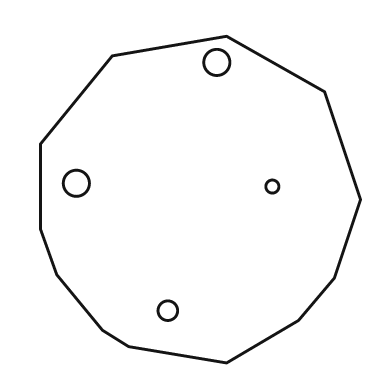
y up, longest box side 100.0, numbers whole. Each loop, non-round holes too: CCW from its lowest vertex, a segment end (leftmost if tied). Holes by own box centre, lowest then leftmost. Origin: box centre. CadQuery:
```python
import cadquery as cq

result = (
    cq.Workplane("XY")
    .moveTo(8.0, -50.0)
    .lineTo(30.0, -37.0)
    .lineTo(41.0, -24.0)
    .lineTo(49.0, 0.0)
    .lineTo(38.0, 33.0)
    .lineTo(8.0, 50.0)
    .lineTo(-27.0, 44.0)
    .lineTo(-49.0, 17.0)
    .lineTo(-49.0, -9.0)
    .lineTo(-44.0, -23.0)
    .lineTo(-30.0, -40.0)
    .lineTo(-22.0, -45.0)
    .close()
    .moveTo(-10.0, -34.0)
    .circle(3.0)
    .moveTo(22.0, 4.0)
    .circle(2.0)
    .moveTo(-38.0, 5.0)
    .circle(4.0)
    .moveTo(5.0, 42.0)
    .circle(4.0)
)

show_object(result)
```